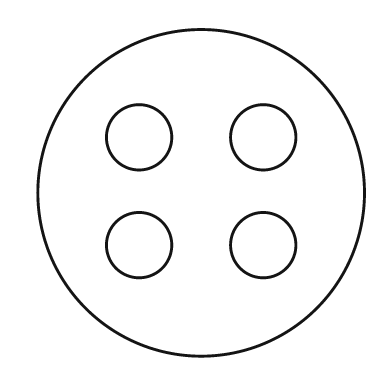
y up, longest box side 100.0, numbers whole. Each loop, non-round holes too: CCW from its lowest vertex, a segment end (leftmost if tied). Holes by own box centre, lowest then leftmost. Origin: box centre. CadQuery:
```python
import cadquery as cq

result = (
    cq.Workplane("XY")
    .moveTo(0.0, 0.0)
    .circle(50.0)
    .moveTo(-19.0, -16.0)
    .circle(10.0)
    .moveTo(19.0, -16.0)
    .circle(10.0)
    .moveTo(-19.0, 17.0)
    .circle(10.0)
    .moveTo(19.0, 17.0)
    .circle(10.0)
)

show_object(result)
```